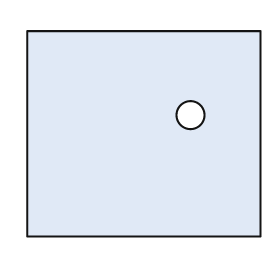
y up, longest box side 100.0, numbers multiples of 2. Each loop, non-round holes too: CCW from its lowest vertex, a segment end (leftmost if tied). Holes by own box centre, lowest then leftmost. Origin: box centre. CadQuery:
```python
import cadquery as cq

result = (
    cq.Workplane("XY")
    .moveTo(-50.0, -44.0)
    .lineTo(50.0, -44.0)
    .lineTo(50.0, 44.0)
    .lineTo(-50.0, 44.0)
    .close()
    .moveTo(20.0, 8.0)
    .circle(6.0)
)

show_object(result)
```